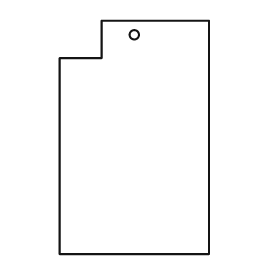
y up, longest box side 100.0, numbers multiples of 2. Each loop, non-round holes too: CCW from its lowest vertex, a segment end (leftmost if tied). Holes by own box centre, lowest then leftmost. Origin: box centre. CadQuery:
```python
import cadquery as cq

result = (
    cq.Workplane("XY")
    .moveTo(-32.0, -50.0)
    .lineTo(32.0, -50.0)
    .lineTo(32.0, 50.0)
    .lineTo(-14.0, 50.0)
    .lineTo(-14.0, 34.0)
    .lineTo(-32.0, 34.0)
    .close()
    .moveTo(0.0, 44.0)
    .circle(2.0)
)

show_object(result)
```